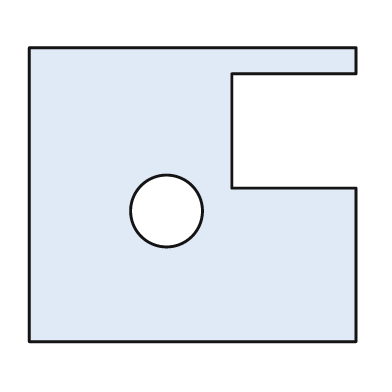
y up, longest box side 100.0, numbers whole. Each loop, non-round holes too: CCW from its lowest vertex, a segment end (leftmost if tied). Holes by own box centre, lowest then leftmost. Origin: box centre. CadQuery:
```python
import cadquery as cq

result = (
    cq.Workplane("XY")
    .moveTo(-50.0, -45.0)
    .lineTo(50.0, -45.0)
    .lineTo(50.0, 2.0)
    .lineTo(12.0, 2.0)
    .lineTo(12.0, 37.0)
    .lineTo(50.0, 37.0)
    .lineTo(50.0, 45.0)
    .lineTo(-50.0, 45.0)
    .close()
    .moveTo(-8.0, -5.0)
    .circle(11.0)
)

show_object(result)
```